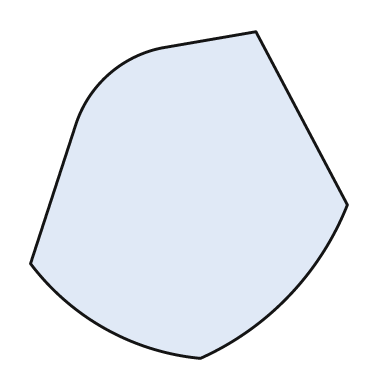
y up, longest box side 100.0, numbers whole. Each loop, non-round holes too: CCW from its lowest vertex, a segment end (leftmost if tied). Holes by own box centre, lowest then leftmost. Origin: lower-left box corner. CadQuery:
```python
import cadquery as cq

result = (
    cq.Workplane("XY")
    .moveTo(52.0, 0.0)
    .threePointArc((79.0, 19.0), (97.0, 47.0))
    .lineTo(69.0, 100.0)
    .lineTo(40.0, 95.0)
    .threePointArc((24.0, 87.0), (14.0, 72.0))
    .lineTo(0.0, 29.0)
    .threePointArc((23.0, 9.0), (52.0, 0.0))
    .close()
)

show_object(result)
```